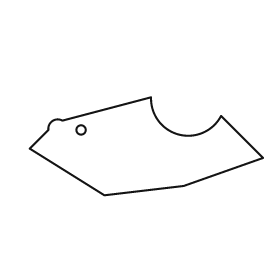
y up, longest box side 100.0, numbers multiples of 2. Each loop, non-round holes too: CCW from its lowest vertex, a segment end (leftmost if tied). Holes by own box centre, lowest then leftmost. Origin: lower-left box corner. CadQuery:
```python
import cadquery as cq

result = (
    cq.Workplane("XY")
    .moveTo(32.0, 0.0)
    .lineTo(66.0, 4.0)
    .lineTo(100.0, 16.0)
    .lineTo(82.0, 34.0)
    .threePointArc((64.0, 26.0), (52.0, 42.0))
    .lineTo(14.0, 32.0)
    .threePointArc((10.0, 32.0), (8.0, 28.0))
    .lineTo(0.0, 20.0)
    .close()
    .moveTo(22.0, 28.0)
    .circle(2.0)
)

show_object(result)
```